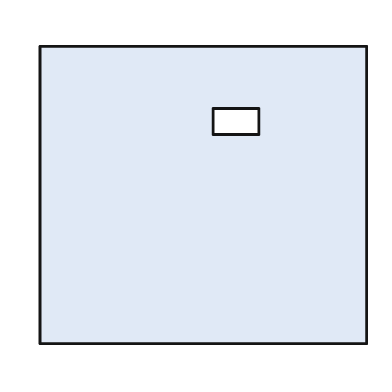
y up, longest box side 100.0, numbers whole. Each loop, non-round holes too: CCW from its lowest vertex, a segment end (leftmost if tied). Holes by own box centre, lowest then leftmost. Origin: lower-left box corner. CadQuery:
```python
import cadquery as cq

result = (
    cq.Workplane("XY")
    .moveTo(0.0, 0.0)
    .lineTo(100.0, 0.0)
    .lineTo(100.0, 91.0)
    .lineTo(0.0, 91.0)
    .close()
    .moveTo(53.0, 64.0)
    .lineTo(67.0, 64.0)
    .lineTo(67.0, 72.0)
    .lineTo(53.0, 72.0)
    .close()
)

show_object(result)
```